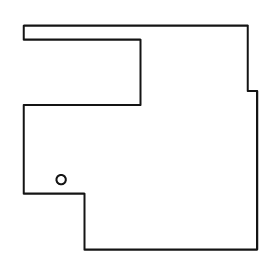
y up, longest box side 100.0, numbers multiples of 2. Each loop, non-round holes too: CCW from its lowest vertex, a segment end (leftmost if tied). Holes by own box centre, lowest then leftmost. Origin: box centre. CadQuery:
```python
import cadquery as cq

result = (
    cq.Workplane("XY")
    .moveTo(-24.0, -48.0)
    .lineTo(50.0, -48.0)
    .lineTo(50.0, 20.0)
    .lineTo(46.0, 20.0)
    .lineTo(46.0, 48.0)
    .lineTo(-50.0, 48.0)
    .lineTo(-50.0, 42.0)
    .lineTo(0.0, 42.0)
    .lineTo(0.0, 14.0)
    .lineTo(-50.0, 14.0)
    .lineTo(-50.0, -24.0)
    .lineTo(-24.0, -24.0)
    .close()
    .moveTo(-34.0, -18.0)
    .circle(2.0)
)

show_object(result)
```